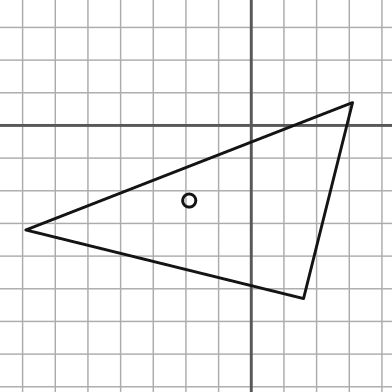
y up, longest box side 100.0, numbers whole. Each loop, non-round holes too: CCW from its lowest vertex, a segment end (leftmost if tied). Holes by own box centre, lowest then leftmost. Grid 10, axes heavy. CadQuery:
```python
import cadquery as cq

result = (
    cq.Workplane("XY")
    .moveTo(16.0, -53.0)
    .lineTo(31.0, 7.0)
    .lineTo(-69.0, -32.0)
    .close()
    .moveTo(-19.0, -23.0)
    .circle(2.0)
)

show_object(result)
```